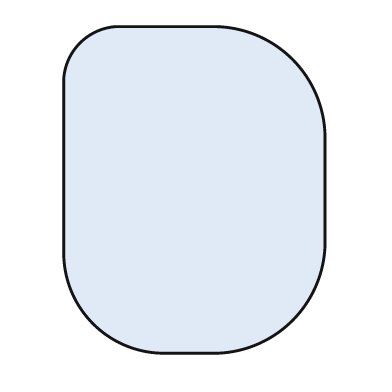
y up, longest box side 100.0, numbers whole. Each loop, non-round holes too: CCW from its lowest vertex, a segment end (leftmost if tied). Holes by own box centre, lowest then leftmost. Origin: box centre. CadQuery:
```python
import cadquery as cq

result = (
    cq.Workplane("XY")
    .moveTo(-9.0, -50.0)
    .lineTo(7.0, -50.0)
    .threePointArc((30.0, -40.0), (40.0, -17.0))
    .lineTo(40.0, 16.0)
    .threePointArc((30.0, 40.0), (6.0, 50.0))
    .lineTo(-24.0, 50.0)
    .threePointArc((-35.0, 45.0), (-40.0, 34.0))
    .lineTo(-40.0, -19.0)
    .threePointArc((-31.0, -41.0), (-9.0, -50.0))
    .close()
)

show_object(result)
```